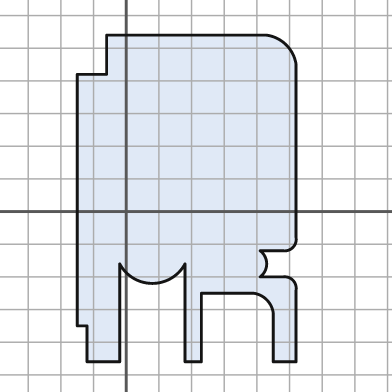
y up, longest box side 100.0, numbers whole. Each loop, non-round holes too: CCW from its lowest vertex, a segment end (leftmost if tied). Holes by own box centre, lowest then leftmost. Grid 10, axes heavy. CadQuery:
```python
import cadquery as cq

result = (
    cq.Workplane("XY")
    .moveTo(-12.0, -46.0)
    .lineTo(-2.0, -46.0)
    .lineTo(-2.0, -16.0)
    .threePointArc((8.0, -22.0), (18.0, -16.0))
    .lineTo(18.0, -46.0)
    .lineTo(23.0, -46.0)
    .lineTo(23.0, -25.0)
    .lineTo(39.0, -25.0)
    .threePointArc((43.0, -27.0), (45.0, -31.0))
    .lineTo(45.0, -46.0)
    .lineTo(52.0, -46.0)
    .lineTo(52.0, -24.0)
    .threePointArc((51.0, -21.0), (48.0, -20.0))
    .lineTo(41.0, -20.0)
    .threePointArc((43.0, -16.0), (41.0, -12.0))
    .lineTo(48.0, -12.0)
    .threePointArc((51.0, -11.0), (52.0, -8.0))
    .lineTo(52.0, 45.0)
    .threePointArc((49.0, 51.0), (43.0, 54.0))
    .lineTo(-6.0, 54.0)
    .lineTo(-6.0, 42.0)
    .lineTo(-15.0, 42.0)
    .lineTo(-15.0, -35.0)
    .lineTo(-12.0, -35.0)
    .close()
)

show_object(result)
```